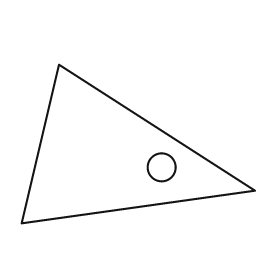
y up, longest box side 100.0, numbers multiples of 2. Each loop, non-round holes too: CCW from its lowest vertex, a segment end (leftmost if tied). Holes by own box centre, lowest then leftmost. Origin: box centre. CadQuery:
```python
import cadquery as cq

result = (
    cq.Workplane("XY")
    .moveTo(-50.0, -34.0)
    .lineTo(50.0, -20.0)
    .lineTo(-34.0, 34.0)
    .close()
    .moveTo(10.0, -10.0)
    .circle(6.0)
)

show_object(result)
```